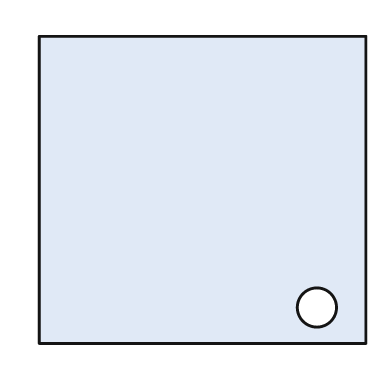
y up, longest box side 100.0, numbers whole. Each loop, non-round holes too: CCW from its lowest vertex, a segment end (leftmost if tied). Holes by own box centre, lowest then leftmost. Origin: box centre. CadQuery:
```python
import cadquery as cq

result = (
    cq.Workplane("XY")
    .moveTo(-50.0, -47.0)
    .lineTo(50.0, -47.0)
    .lineTo(50.0, 47.0)
    .lineTo(-50.0, 47.0)
    .close()
    .moveTo(35.0, -36.0)
    .circle(6.0)
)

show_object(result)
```